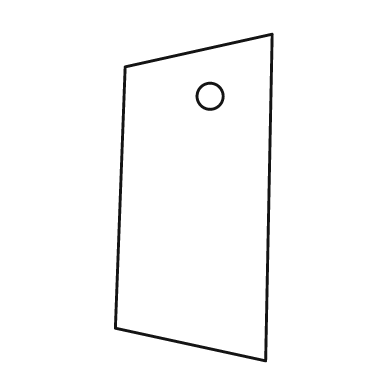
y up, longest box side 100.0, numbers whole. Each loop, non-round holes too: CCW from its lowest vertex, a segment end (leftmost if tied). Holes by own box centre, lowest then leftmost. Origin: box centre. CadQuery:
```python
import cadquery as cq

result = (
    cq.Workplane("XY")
    .moveTo(22.0, -50.0)
    .lineTo(24.0, 50.0)
    .lineTo(-21.0, 40.0)
    .lineTo(-24.0, -40.0)
    .close()
    .moveTo(5.0, 31.0)
    .circle(4.0)
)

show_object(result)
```